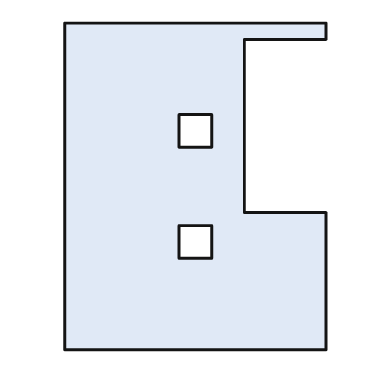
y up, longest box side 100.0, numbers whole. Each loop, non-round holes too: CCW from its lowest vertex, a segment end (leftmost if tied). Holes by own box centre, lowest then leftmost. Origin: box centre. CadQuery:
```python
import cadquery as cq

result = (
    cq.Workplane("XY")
    .moveTo(-40.0, -50.0)
    .lineTo(40.0, -50.0)
    .lineTo(40.0, -8.0)
    .lineTo(15.0, -8.0)
    .lineTo(15.0, 45.0)
    .lineTo(40.0, 45.0)
    .lineTo(40.0, 50.0)
    .lineTo(-40.0, 50.0)
    .close()
    .moveTo(-5.0, -22.0)
    .lineTo(5.0, -22.0)
    .lineTo(5.0, -12.0)
    .lineTo(-5.0, -12.0)
    .close()
    .moveTo(-5.0, 12.0)
    .lineTo(5.0, 12.0)
    .lineTo(5.0, 22.0)
    .lineTo(-5.0, 22.0)
    .close()
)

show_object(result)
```